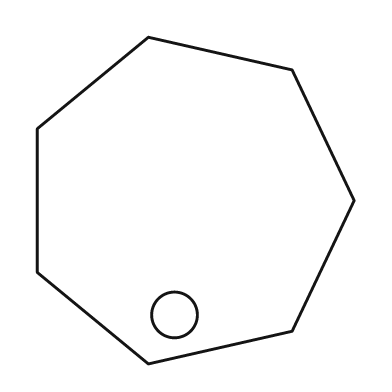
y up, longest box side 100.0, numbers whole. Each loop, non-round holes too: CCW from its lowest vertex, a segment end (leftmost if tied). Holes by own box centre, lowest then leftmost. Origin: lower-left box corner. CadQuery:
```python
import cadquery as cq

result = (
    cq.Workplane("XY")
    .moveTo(34.0, 0.0)
    .lineTo(78.0, 10.0)
    .lineTo(97.0, 50.0)
    .lineTo(78.0, 90.0)
    .lineTo(34.0, 100.0)
    .lineTo(0.0, 72.0)
    .lineTo(0.0, 28.0)
    .close()
    .moveTo(42.0, 15.0)
    .circle(7.0)
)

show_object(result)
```